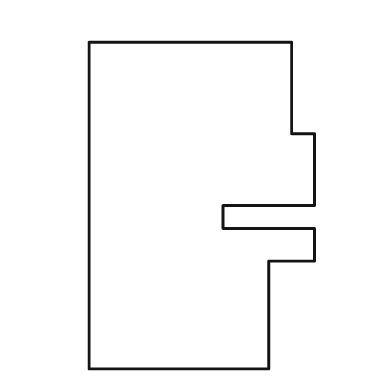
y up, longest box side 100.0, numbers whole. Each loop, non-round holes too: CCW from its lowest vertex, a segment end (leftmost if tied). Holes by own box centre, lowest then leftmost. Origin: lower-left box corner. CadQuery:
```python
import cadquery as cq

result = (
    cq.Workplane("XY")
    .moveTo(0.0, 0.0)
    .lineTo(55.0, 0.0)
    .lineTo(55.0, 33.0)
    .lineTo(69.0, 33.0)
    .lineTo(69.0, 43.0)
    .lineTo(41.0, 43.0)
    .lineTo(41.0, 50.0)
    .lineTo(69.0, 50.0)
    .lineTo(69.0, 72.0)
    .lineTo(62.0, 72.0)
    .lineTo(62.0, 100.0)
    .lineTo(0.0, 100.0)
    .close()
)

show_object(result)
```